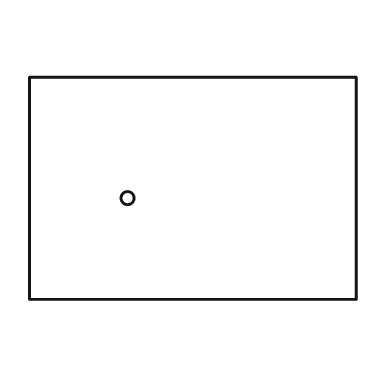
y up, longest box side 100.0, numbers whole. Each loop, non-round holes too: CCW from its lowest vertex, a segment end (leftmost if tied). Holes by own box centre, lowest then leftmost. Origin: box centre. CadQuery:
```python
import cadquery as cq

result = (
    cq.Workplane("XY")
    .moveTo(-50.0, -34.0)
    .lineTo(50.0, -34.0)
    .lineTo(50.0, 34.0)
    .lineTo(-50.0, 34.0)
    .close()
    .moveTo(-20.0, -3.0)
    .circle(2.0)
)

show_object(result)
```